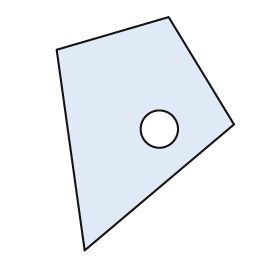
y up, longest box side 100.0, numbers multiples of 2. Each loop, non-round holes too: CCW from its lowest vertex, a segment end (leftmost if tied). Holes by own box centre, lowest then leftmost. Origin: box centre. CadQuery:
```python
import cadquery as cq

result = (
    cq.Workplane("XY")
    .moveTo(-26.0, -50.0)
    .lineTo(38.0, 4.0)
    .lineTo(10.0, 50.0)
    .lineTo(-38.0, 36.0)
    .close()
    .moveTo(6.0, 2.0)
    .circle(8.0)
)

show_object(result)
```